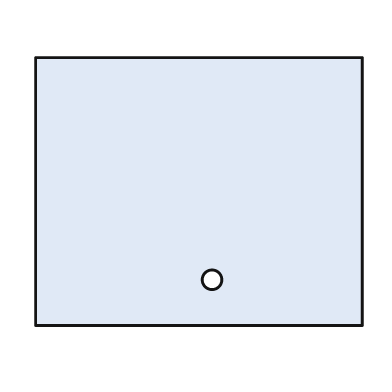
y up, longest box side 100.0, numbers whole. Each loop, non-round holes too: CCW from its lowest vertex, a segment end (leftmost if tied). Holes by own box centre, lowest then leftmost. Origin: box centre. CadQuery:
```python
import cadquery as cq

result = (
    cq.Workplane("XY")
    .moveTo(-50.0, -41.0)
    .lineTo(50.0, -41.0)
    .lineTo(50.0, 41.0)
    .lineTo(-50.0, 41.0)
    .close()
    .moveTo(4.0, -27.0)
    .circle(3.0)
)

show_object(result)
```